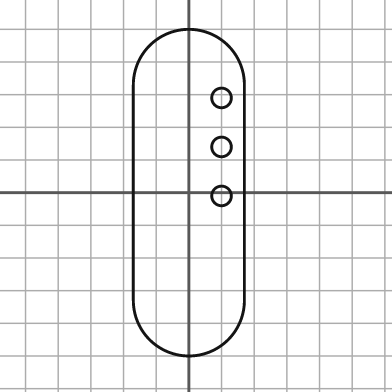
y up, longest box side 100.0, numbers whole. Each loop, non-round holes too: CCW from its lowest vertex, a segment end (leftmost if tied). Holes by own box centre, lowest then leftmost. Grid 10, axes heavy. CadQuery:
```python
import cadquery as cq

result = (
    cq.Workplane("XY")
    .moveTo(-17.0, -33.0)
    .threePointArc((0.0, -50.0), (17.0, -33.0))
    .lineTo(17.0, 33.0)
    .threePointArc((0.0, 50.0), (-17.0, 33.0))
    .close()
    .moveTo(10.0, -1.0)
    .circle(3.0)
    .moveTo(10.0, 14.0)
    .circle(3.0)
    .moveTo(10.0, 29.0)
    .circle(3.0)
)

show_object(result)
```